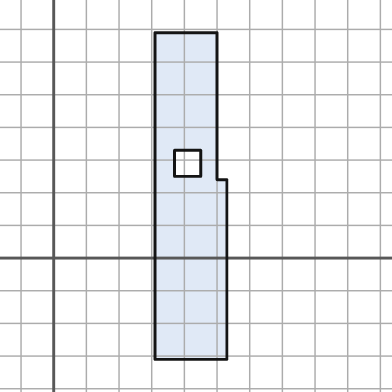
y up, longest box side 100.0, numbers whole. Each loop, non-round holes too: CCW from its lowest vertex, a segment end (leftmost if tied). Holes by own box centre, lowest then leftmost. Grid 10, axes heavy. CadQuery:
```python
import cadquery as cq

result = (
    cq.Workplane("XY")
    .moveTo(31.0, -31.0)
    .lineTo(53.0, -31.0)
    .lineTo(53.0, 24.0)
    .lineTo(50.0, 24.0)
    .lineTo(50.0, 69.0)
    .lineTo(31.0, 69.0)
    .close()
    .moveTo(37.0, 25.0)
    .lineTo(45.0, 25.0)
    .lineTo(45.0, 33.0)
    .lineTo(37.0, 33.0)
    .close()
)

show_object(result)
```